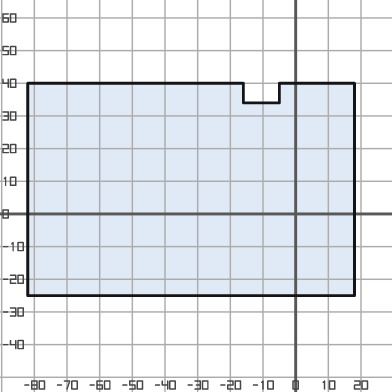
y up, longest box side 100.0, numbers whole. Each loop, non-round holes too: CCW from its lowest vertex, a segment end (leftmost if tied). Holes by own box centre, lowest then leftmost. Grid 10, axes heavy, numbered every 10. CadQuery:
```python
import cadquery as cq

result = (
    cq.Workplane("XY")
    .moveTo(-82.0, -25.0)
    .lineTo(18.0, -25.0)
    .lineTo(18.0, 40.0)
    .lineTo(-5.0, 40.0)
    .lineTo(-5.0, 34.0)
    .lineTo(-16.0, 34.0)
    .lineTo(-16.0, 40.0)
    .lineTo(-82.0, 40.0)
    .close()
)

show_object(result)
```